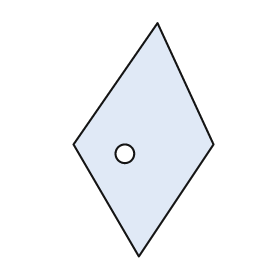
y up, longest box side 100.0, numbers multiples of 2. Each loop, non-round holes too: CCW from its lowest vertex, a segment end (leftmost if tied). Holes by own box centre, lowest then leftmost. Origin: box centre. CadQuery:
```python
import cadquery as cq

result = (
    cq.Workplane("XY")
    .moveTo(-2.0, -50.0)
    .lineTo(30.0, -2.0)
    .lineTo(6.0, 50.0)
    .lineTo(-30.0, -2.0)
    .close()
    .moveTo(-8.0, -6.0)
    .circle(4.0)
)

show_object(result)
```